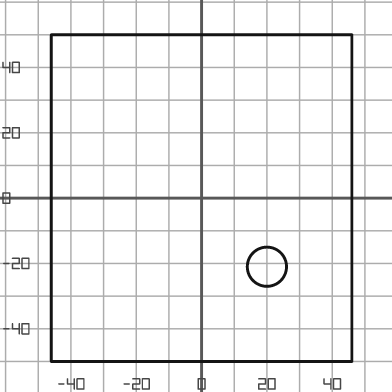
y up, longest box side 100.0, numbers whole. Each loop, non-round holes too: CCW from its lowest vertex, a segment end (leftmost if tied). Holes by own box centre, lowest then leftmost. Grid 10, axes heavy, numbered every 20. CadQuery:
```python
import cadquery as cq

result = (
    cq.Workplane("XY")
    .moveTo(-46.0, -50.0)
    .lineTo(46.0, -50.0)
    .lineTo(46.0, 50.0)
    .lineTo(-46.0, 50.0)
    .close()
    .moveTo(20.0, -21.0)
    .circle(6.0)
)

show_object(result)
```